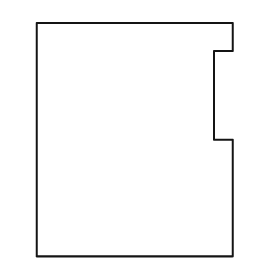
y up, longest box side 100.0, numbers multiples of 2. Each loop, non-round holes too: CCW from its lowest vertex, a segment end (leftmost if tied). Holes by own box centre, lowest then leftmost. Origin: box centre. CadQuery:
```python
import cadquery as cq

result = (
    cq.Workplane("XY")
    .moveTo(-42.0, -50.0)
    .lineTo(42.0, -50.0)
    .lineTo(42.0, 0.0)
    .lineTo(34.0, 0.0)
    .lineTo(34.0, 38.0)
    .lineTo(42.0, 38.0)
    .lineTo(42.0, 50.0)
    .lineTo(-42.0, 50.0)
    .close()
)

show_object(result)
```